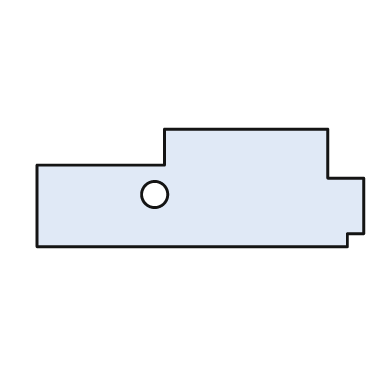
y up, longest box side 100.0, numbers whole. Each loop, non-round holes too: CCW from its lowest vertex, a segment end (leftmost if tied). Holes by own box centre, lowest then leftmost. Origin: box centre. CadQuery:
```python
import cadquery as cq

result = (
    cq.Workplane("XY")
    .moveTo(-50.0, -18.0)
    .lineTo(45.0, -18.0)
    .lineTo(45.0, -14.0)
    .lineTo(50.0, -14.0)
    .lineTo(50.0, 3.0)
    .lineTo(39.0, 3.0)
    .lineTo(39.0, 18.0)
    .lineTo(-11.0, 18.0)
    .lineTo(-11.0, 7.0)
    .lineTo(-50.0, 7.0)
    .close()
    .moveTo(-14.0, -2.0)
    .circle(4.0)
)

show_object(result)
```